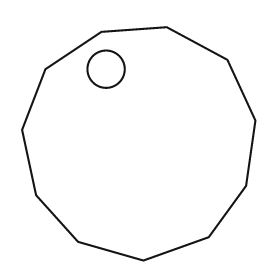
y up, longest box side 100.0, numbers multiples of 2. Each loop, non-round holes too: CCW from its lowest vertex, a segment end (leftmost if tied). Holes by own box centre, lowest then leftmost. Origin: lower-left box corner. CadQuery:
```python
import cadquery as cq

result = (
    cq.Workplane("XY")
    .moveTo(52.0, 0.0)
    .lineTo(80.0, 10.0)
    .lineTo(96.0, 32.0)
    .lineTo(100.0, 60.0)
    .lineTo(88.0, 86.0)
    .lineTo(62.0, 100.0)
    .lineTo(34.0, 98.0)
    .lineTo(10.0, 82.0)
    .lineTo(0.0, 56.0)
    .lineTo(6.0, 28.0)
    .lineTo(24.0, 8.0)
    .close()
    .moveTo(36.0, 82.0)
    .circle(8.0)
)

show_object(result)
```